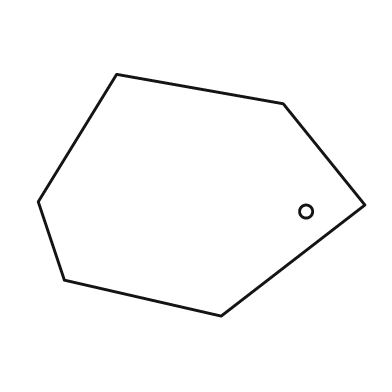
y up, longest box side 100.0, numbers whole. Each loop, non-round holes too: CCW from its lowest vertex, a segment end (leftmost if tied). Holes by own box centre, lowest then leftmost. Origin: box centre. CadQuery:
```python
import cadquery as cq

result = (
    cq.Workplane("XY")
    .moveTo(6.0, -37.0)
    .lineTo(50.0, -3.0)
    .lineTo(25.0, 28.0)
    .lineTo(-26.0, 37.0)
    .lineTo(-50.0, -2.0)
    .lineTo(-42.0, -26.0)
    .close()
    .moveTo(32.0, -5.0)
    .circle(2.0)
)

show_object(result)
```